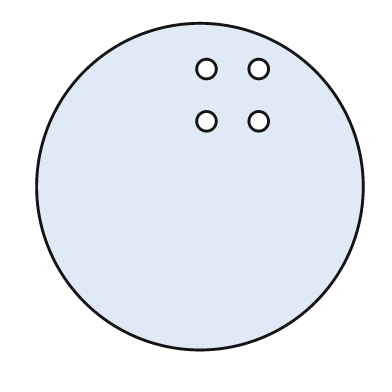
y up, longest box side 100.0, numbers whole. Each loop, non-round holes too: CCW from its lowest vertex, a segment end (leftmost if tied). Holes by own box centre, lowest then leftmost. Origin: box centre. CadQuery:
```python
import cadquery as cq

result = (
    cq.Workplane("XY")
    .moveTo(0.0, 0.0)
    .circle(50.0)
    .moveTo(2.0, 20.0)
    .circle(3.0)
    .moveTo(18.0, 20.0)
    .circle(3.0)
    .moveTo(2.0, 36.0)
    .circle(3.0)
    .moveTo(18.0, 36.0)
    .circle(3.0)
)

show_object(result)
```